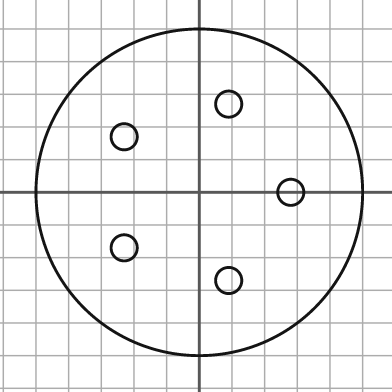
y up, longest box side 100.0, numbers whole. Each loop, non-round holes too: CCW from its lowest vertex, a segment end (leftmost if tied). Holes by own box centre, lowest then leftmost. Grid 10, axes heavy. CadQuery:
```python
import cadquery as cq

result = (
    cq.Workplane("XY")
    .moveTo(0.0, 0.0)
    .circle(50.0)
    .moveTo(9.0, -27.0)
    .circle(4.0)
    .moveTo(-23.0, -17.0)
    .circle(4.0)
    .moveTo(28.0, 0.0)
    .circle(4.0)
    .moveTo(-23.0, 17.0)
    .circle(4.0)
    .moveTo(9.0, 27.0)
    .circle(4.0)
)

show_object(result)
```